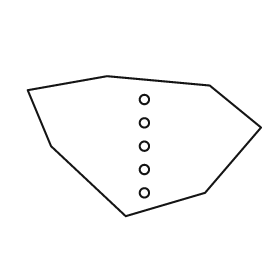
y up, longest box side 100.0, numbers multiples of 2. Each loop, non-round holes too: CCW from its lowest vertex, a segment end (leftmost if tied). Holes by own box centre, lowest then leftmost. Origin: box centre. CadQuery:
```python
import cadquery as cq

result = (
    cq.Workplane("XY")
    .moveTo(-8.0, -30.0)
    .lineTo(26.0, -20.0)
    .lineTo(50.0, 8.0)
    .lineTo(28.0, 26.0)
    .lineTo(-16.0, 30.0)
    .lineTo(-50.0, 24.0)
    .lineTo(-40.0, 0.0)
    .close()
    .moveTo(0.0, -20.0)
    .circle(2.0)
    .moveTo(0.0, -10.0)
    .circle(2.0)
    .moveTo(0.0, 0.0)
    .circle(2.0)
    .moveTo(0.0, 10.0)
    .circle(2.0)
    .moveTo(0.0, 20.0)
    .circle(2.0)
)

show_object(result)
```